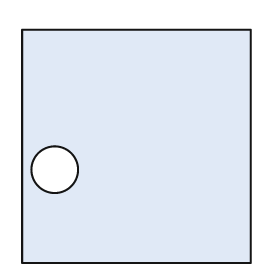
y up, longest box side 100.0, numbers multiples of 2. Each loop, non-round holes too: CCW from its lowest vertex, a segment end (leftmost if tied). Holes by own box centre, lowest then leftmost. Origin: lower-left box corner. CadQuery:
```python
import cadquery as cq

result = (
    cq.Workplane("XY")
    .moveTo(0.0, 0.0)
    .lineTo(98.0, 0.0)
    .lineTo(98.0, 100.0)
    .lineTo(0.0, 100.0)
    .close()
    .moveTo(14.0, 40.0)
    .circle(10.0)
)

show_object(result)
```